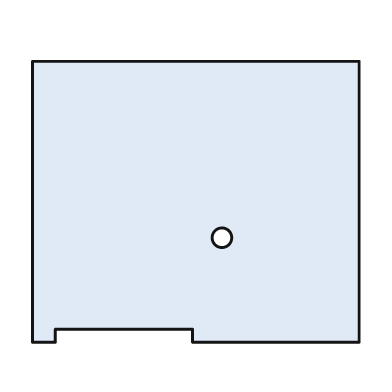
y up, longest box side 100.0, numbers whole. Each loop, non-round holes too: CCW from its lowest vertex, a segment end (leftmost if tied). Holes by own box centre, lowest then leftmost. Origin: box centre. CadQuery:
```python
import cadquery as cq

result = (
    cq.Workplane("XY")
    .moveTo(-50.0, -43.0)
    .lineTo(-43.0, -43.0)
    .lineTo(-43.0, -39.0)
    .lineTo(-1.0, -39.0)
    .lineTo(-1.0, -43.0)
    .lineTo(50.0, -43.0)
    .lineTo(50.0, 43.0)
    .lineTo(-50.0, 43.0)
    .close()
    .moveTo(8.0, -11.0)
    .circle(3.0)
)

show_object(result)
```